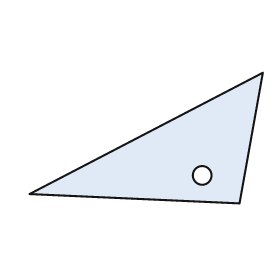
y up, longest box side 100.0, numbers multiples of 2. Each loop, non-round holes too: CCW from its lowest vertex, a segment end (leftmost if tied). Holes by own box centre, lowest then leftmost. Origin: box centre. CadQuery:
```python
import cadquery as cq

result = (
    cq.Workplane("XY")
    .moveTo(40.0, -28.0)
    .lineTo(50.0, 28.0)
    .lineTo(-50.0, -24.0)
    .close()
    .moveTo(24.0, -16.0)
    .circle(4.0)
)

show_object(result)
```